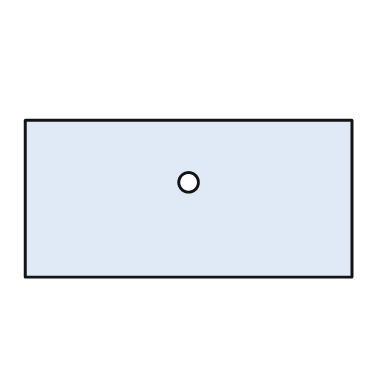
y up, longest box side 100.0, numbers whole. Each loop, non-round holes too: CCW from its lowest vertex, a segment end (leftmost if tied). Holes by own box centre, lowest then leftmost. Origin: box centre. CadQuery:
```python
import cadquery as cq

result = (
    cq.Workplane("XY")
    .moveTo(-50.0, -24.0)
    .lineTo(50.0, -24.0)
    .lineTo(50.0, 24.0)
    .lineTo(-50.0, 24.0)
    .close()
    .moveTo(0.0, 5.0)
    .circle(3.0)
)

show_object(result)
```